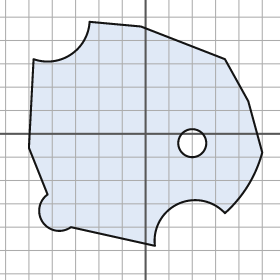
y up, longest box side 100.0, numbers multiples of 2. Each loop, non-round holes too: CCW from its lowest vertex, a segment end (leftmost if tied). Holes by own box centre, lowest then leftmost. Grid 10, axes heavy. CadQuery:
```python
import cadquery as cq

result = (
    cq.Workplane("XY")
    .moveTo(4.0, -48.0)
    .threePointArc((14.0, -30.0), (34.0, -34.0))
    .threePointArc((44.0, -22.0), (50.0, -8.0))
    .lineTo(44.0, 14.0)
    .lineTo(34.0, 32.0)
    .lineTo(-2.0, 46.0)
    .lineTo(-24.0, 48.0)
    .threePointArc((-32.0, 34.0), (-48.0, 32.0))
    .lineTo(-50.0, -6.0)
    .lineTo(-42.0, -26.0)
    .threePointArc((-44.0, -38.0), (-32.0, -40.0))
    .close()
    .moveTo(20.0, -4.0)
    .circle(6.0)
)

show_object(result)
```